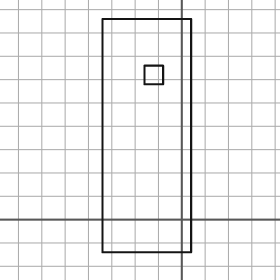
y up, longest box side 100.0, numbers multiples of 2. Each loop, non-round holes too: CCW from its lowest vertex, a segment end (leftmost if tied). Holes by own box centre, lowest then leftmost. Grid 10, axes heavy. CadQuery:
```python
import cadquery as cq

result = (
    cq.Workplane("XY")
    .moveTo(-34.0, -14.0)
    .lineTo(4.0, -14.0)
    .lineTo(4.0, 86.0)
    .lineTo(-34.0, 86.0)
    .close()
    .moveTo(-16.0, 58.0)
    .lineTo(-8.0, 58.0)
    .lineTo(-8.0, 66.0)
    .lineTo(-16.0, 66.0)
    .close()
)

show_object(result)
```